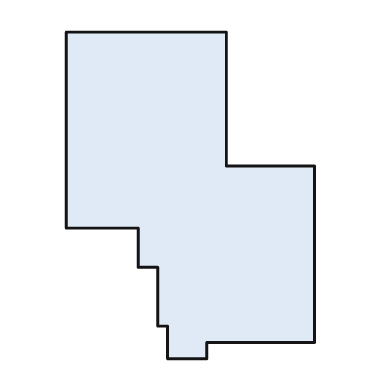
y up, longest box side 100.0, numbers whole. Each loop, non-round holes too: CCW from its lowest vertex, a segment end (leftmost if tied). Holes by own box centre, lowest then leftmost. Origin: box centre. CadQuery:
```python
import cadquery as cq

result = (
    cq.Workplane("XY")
    .moveTo(-7.0, -50.0)
    .lineTo(5.0, -50.0)
    .lineTo(5.0, -45.0)
    .lineTo(38.0, -45.0)
    .lineTo(38.0, 9.0)
    .lineTo(11.0, 9.0)
    .lineTo(11.0, 50.0)
    .lineTo(-38.0, 50.0)
    .lineTo(-38.0, -10.0)
    .lineTo(-16.0, -10.0)
    .lineTo(-16.0, -22.0)
    .lineTo(-10.0, -22.0)
    .lineTo(-10.0, -40.0)
    .lineTo(-7.0, -40.0)
    .close()
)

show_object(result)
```